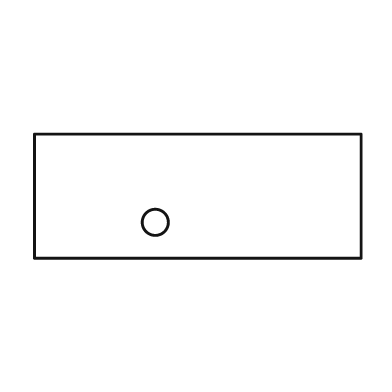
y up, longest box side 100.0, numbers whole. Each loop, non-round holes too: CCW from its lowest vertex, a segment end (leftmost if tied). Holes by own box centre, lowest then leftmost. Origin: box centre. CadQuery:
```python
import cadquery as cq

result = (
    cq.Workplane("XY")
    .moveTo(-50.0, -19.0)
    .lineTo(50.0, -19.0)
    .lineTo(50.0, 19.0)
    .lineTo(-50.0, 19.0)
    .close()
    .moveTo(-13.0, -8.0)
    .circle(4.0)
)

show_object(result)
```